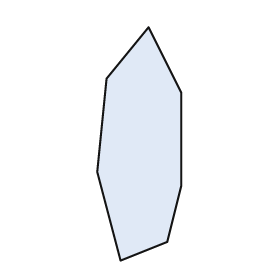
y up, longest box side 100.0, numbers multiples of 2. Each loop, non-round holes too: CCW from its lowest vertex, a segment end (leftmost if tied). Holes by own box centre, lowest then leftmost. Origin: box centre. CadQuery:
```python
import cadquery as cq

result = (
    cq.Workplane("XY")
    .moveTo(-8.0, -50.0)
    .lineTo(12.0, -42.0)
    .lineTo(18.0, -18.0)
    .lineTo(18.0, 22.0)
    .lineTo(4.0, 50.0)
    .lineTo(-14.0, 28.0)
    .lineTo(-18.0, -12.0)
    .close()
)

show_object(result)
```